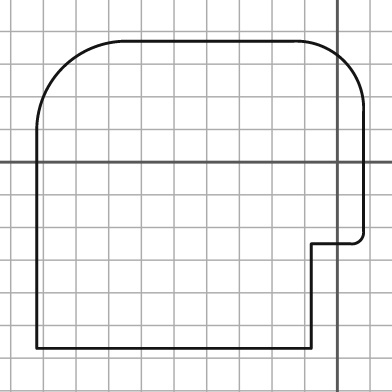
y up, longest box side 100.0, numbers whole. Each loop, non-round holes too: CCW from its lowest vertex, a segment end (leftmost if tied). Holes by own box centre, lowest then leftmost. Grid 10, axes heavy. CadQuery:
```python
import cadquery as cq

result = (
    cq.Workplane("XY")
    .moveTo(-92.0, -57.0)
    .lineTo(-8.0, -57.0)
    .lineTo(-8.0, -25.0)
    .lineTo(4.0, -25.0)
    .threePointArc((7.0, -24.0), (8.0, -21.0))
    .lineTo(8.0, 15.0)
    .threePointArc((2.0, 31.0), (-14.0, 37.0))
    .lineTo(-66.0, 37.0)
    .threePointArc((-84.0, 29.0), (-92.0, 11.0))
    .close()
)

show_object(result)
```